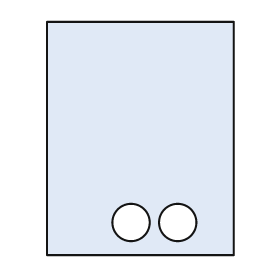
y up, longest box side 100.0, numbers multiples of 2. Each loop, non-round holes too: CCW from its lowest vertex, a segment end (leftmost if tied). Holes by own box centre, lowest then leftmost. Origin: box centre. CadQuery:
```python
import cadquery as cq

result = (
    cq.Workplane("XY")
    .moveTo(-40.0, -50.0)
    .lineTo(40.0, -50.0)
    .lineTo(40.0, 50.0)
    .lineTo(-40.0, 50.0)
    .close()
    .moveTo(-4.0, -36.0)
    .circle(8.0)
    .moveTo(16.0, -36.0)
    .circle(8.0)
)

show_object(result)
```